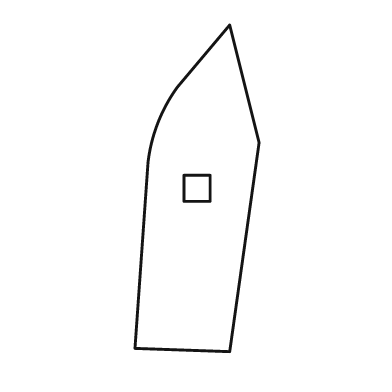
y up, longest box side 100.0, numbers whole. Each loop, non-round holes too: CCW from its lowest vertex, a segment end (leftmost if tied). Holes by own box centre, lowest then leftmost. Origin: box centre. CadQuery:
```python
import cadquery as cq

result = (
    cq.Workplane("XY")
    .moveTo(10.0, -50.0)
    .lineTo(19.0, 14.0)
    .lineTo(10.0, 50.0)
    .lineTo(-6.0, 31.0)
    .threePointArc((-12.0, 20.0), (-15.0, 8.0))
    .lineTo(-19.0, -49.0)
    .close()
    .moveTo(-4.0, -4.0)
    .lineTo(4.0, -4.0)
    .lineTo(4.0, 4.0)
    .lineTo(-4.0, 4.0)
    .close()
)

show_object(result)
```